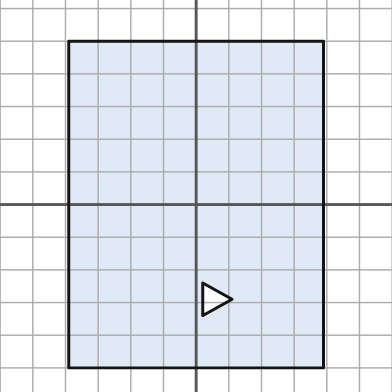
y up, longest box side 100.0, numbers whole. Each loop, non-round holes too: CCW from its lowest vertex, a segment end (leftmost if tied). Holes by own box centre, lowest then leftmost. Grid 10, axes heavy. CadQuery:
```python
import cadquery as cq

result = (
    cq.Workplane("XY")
    .moveTo(-39.0, -50.0)
    .lineTo(39.0, -50.0)
    .lineTo(39.0, 50.0)
    .lineTo(-39.0, 50.0)
    .close()
    .moveTo(2.0, -34.0)
    .lineTo(11.0, -29.0)
    .lineTo(2.0, -24.0)
    .close()
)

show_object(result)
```